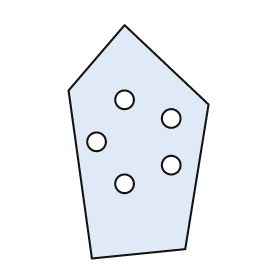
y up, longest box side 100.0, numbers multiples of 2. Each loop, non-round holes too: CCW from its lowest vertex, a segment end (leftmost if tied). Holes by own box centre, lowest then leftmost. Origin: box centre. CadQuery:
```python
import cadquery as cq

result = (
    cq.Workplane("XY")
    .moveTo(-20.0, -50.0)
    .lineTo(20.0, -46.0)
    .lineTo(30.0, 16.0)
    .lineTo(-6.0, 50.0)
    .lineTo(-30.0, 22.0)
    .close()
    .moveTo(-6.0, -18.0)
    .circle(4.0)
    .moveTo(14.0, -10.0)
    .circle(4.0)
    .moveTo(-18.0, 0.0)
    .circle(4.0)
    .moveTo(14.0, 10.0)
    .circle(4.0)
    .moveTo(-6.0, 18.0)
    .circle(4.0)
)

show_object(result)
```